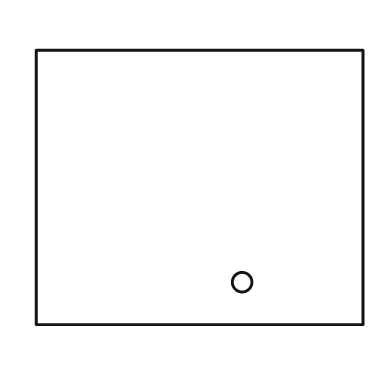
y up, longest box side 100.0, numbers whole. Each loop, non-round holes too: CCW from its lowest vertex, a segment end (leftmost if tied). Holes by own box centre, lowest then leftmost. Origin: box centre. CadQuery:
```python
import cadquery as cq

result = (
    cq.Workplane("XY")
    .moveTo(-50.0, -42.0)
    .lineTo(50.0, -42.0)
    .lineTo(50.0, 42.0)
    .lineTo(-50.0, 42.0)
    .close()
    .moveTo(13.0, -29.0)
    .circle(3.0)
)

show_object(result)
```